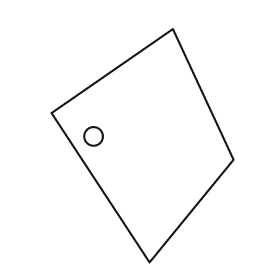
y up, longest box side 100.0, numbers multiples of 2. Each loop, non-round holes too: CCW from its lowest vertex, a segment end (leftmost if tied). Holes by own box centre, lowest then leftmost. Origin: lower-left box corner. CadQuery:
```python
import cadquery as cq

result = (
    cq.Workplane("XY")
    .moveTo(42.0, 0.0)
    .lineTo(78.0, 44.0)
    .lineTo(52.0, 100.0)
    .lineTo(0.0, 64.0)
    .close()
    .moveTo(18.0, 54.0)
    .circle(4.0)
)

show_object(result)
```